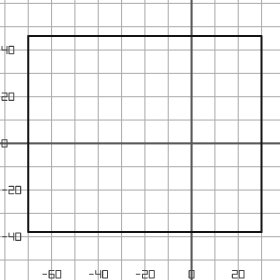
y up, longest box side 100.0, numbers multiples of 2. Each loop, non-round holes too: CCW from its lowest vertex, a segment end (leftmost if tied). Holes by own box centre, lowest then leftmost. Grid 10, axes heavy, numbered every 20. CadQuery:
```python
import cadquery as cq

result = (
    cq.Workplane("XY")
    .moveTo(-70.0, -38.0)
    .lineTo(30.0, -38.0)
    .lineTo(30.0, 46.0)
    .lineTo(-70.0, 46.0)
    .close()
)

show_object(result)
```